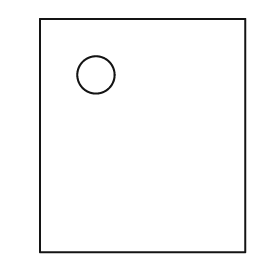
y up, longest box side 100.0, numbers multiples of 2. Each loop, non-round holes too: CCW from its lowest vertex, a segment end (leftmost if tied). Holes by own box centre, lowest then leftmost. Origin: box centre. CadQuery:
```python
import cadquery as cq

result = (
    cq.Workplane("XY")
    .moveTo(-44.0, -50.0)
    .lineTo(44.0, -50.0)
    .lineTo(44.0, 50.0)
    .lineTo(-44.0, 50.0)
    .close()
    .moveTo(-20.0, 26.0)
    .circle(8.0)
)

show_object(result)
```